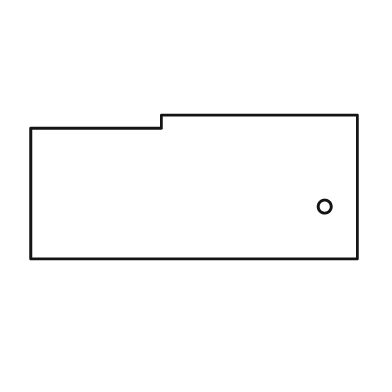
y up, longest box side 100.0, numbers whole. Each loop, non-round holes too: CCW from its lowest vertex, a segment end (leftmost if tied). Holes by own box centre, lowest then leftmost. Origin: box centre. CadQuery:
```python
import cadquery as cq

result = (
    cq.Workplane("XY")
    .moveTo(-50.0, -22.0)
    .lineTo(50.0, -22.0)
    .lineTo(50.0, 22.0)
    .lineTo(-10.0, 22.0)
    .lineTo(-10.0, 18.0)
    .lineTo(-50.0, 18.0)
    .close()
    .moveTo(40.0, -6.0)
    .circle(2.0)
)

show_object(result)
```